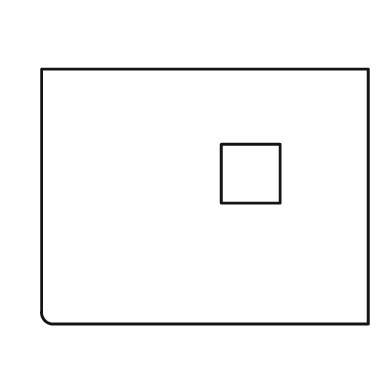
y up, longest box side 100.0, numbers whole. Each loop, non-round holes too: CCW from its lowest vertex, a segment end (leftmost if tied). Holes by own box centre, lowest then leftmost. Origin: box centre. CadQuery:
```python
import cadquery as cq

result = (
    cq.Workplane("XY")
    .moveTo(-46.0, -39.0)
    .lineTo(50.0, -39.0)
    .lineTo(50.0, 39.0)
    .lineTo(-50.0, 39.0)
    .lineTo(-50.0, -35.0)
    .threePointArc((-49.0, -38.0), (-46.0, -39.0))
    .close()
    .moveTo(5.0, -2.0)
    .lineTo(23.0, -2.0)
    .lineTo(23.0, 16.0)
    .lineTo(5.0, 16.0)
    .close()
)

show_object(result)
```